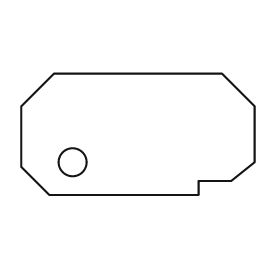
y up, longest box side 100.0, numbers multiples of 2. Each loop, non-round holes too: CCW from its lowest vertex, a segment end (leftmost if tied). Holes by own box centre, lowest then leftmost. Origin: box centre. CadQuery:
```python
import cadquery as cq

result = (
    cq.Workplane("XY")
    .moveTo(-38.0, -26.0)
    .lineTo(26.0, -26.0)
    .lineTo(26.0, -20.0)
    .lineTo(40.0, -20.0)
    .lineTo(50.0, -12.0)
    .lineTo(50.0, 12.0)
    .lineTo(36.0, 26.0)
    .lineTo(-36.0, 26.0)
    .lineTo(-50.0, 12.0)
    .lineTo(-50.0, -14.0)
    .close()
    .moveTo(-28.0, -12.0)
    .circle(6.0)
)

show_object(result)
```